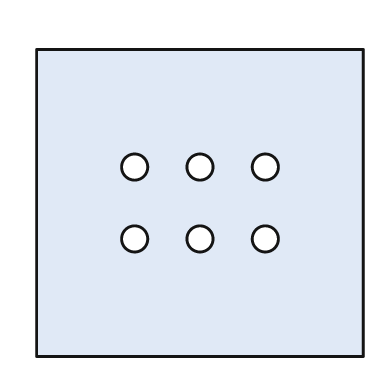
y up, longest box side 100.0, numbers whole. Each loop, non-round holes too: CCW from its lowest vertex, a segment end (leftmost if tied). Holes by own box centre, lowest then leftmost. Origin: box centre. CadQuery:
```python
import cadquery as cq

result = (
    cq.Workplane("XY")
    .moveTo(-50.0, -47.0)
    .lineTo(50.0, -47.0)
    .lineTo(50.0, 47.0)
    .lineTo(-50.0, 47.0)
    .close()
    .moveTo(-20.0, -11.0)
    .circle(4.0)
    .moveTo(0.0, -11.0)
    .circle(4.0)
    .moveTo(20.0, -11.0)
    .circle(4.0)
    .moveTo(-20.0, 11.0)
    .circle(4.0)
    .moveTo(0.0, 11.0)
    .circle(4.0)
    .moveTo(20.0, 11.0)
    .circle(4.0)
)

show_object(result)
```